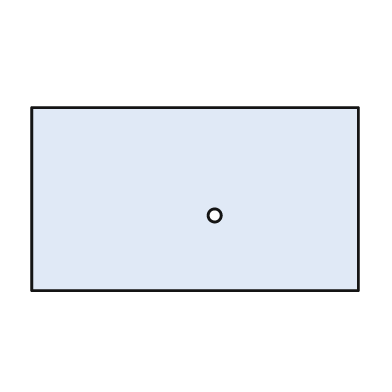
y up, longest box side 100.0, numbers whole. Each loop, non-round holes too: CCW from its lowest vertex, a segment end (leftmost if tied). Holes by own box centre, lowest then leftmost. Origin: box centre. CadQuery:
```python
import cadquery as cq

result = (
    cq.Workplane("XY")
    .moveTo(-50.0, -28.0)
    .lineTo(50.0, -28.0)
    .lineTo(50.0, 28.0)
    .lineTo(-50.0, 28.0)
    .close()
    .moveTo(6.0, -5.0)
    .circle(2.0)
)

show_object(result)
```